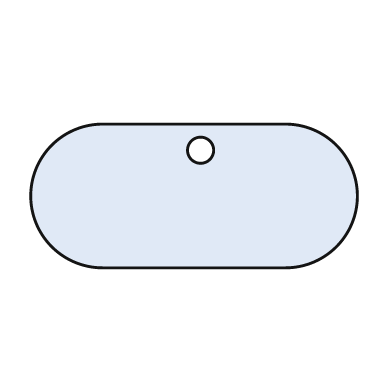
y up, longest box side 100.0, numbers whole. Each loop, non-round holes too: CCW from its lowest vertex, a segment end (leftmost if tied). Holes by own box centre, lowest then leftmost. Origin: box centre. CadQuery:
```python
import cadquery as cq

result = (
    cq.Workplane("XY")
    .moveTo(-28.0, -22.0)
    .lineTo(28.0, -22.0)
    .threePointArc((50.0, 0.0), (28.0, 22.0))
    .lineTo(-28.0, 22.0)
    .threePointArc((-50.0, 0.0), (-28.0, -22.0))
    .close()
    .moveTo(2.0, 14.0)
    .circle(4.0)
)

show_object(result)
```